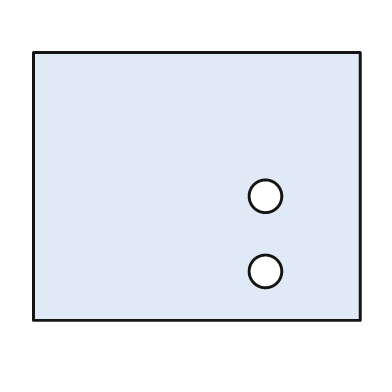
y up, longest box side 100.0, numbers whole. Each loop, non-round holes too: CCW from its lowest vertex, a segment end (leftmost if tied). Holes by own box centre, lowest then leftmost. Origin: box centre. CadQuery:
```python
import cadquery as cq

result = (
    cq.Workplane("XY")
    .moveTo(-50.0, -41.0)
    .lineTo(50.0, -41.0)
    .lineTo(50.0, 41.0)
    .lineTo(-50.0, 41.0)
    .close()
    .moveTo(21.0, -26.0)
    .circle(5.0)
    .moveTo(21.0, -3.0)
    .circle(5.0)
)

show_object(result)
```